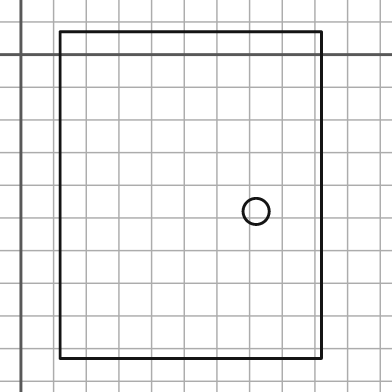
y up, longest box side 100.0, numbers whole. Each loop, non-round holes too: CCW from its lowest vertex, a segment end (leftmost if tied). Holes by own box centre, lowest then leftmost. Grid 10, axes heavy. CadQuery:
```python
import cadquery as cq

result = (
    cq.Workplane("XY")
    .moveTo(12.0, -93.0)
    .lineTo(92.0, -93.0)
    .lineTo(92.0, 7.0)
    .lineTo(12.0, 7.0)
    .close()
    .moveTo(72.0, -48.0)
    .circle(4.0)
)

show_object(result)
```